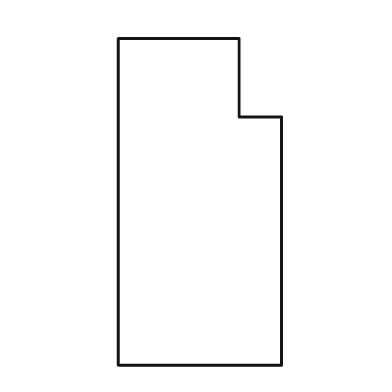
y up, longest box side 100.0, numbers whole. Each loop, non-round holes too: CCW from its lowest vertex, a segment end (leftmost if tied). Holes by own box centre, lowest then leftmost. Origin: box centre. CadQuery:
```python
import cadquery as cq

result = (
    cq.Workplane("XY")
    .moveTo(-25.0, -50.0)
    .lineTo(25.0, -50.0)
    .lineTo(25.0, 26.0)
    .lineTo(12.0, 26.0)
    .lineTo(12.0, 50.0)
    .lineTo(-25.0, 50.0)
    .close()
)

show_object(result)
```